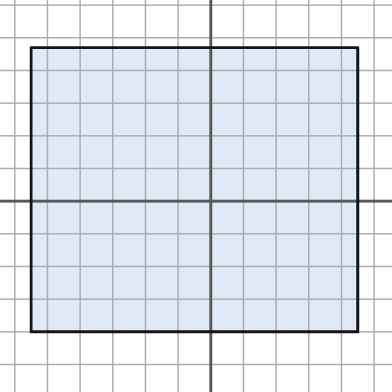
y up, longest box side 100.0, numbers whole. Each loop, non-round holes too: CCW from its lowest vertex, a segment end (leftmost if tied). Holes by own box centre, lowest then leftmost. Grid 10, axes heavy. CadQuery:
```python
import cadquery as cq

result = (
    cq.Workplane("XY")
    .moveTo(-55.0, -40.0)
    .lineTo(45.0, -40.0)
    .lineTo(45.0, 47.0)
    .lineTo(-55.0, 47.0)
    .close()
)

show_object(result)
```